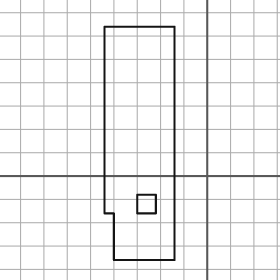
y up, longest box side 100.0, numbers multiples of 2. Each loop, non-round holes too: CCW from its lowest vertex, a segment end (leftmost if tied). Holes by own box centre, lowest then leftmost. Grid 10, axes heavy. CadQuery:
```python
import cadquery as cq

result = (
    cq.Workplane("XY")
    .moveTo(-40.0, -36.0)
    .lineTo(-14.0, -36.0)
    .lineTo(-14.0, 64.0)
    .lineTo(-44.0, 64.0)
    .lineTo(-44.0, -16.0)
    .lineTo(-40.0, -16.0)
    .close()
    .moveTo(-30.0, -16.0)
    .lineTo(-22.0, -16.0)
    .lineTo(-22.0, -8.0)
    .lineTo(-30.0, -8.0)
    .close()
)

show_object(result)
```